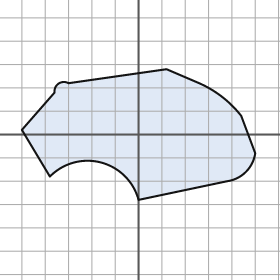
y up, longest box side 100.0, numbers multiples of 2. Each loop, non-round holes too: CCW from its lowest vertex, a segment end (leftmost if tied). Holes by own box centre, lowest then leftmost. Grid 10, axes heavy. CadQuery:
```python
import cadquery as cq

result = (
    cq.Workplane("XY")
    .moveTo(0.0, -28.0)
    .lineTo(38.0, -20.0)
    .threePointArc((46.0, -16.0), (50.0, -8.0))
    .lineTo(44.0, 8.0)
    .threePointArc((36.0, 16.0), (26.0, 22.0))
    .lineTo(12.0, 28.0)
    .lineTo(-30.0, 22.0)
    .threePointArc((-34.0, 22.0), (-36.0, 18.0))
    .lineTo(-50.0, 2.0)
    .lineTo(-38.0, -18.0)
    .threePointArc((-16.0, -12.0), (0.0, -28.0))
    .close()
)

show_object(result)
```